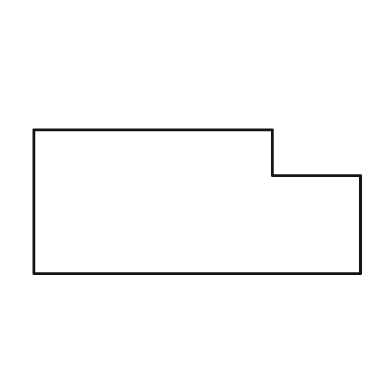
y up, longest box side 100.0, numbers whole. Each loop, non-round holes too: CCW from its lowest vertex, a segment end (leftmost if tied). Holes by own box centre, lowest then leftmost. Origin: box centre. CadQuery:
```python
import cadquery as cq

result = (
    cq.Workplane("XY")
    .moveTo(-50.0, -22.0)
    .lineTo(50.0, -22.0)
    .lineTo(50.0, 8.0)
    .lineTo(23.0, 8.0)
    .lineTo(23.0, 22.0)
    .lineTo(-50.0, 22.0)
    .close()
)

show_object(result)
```